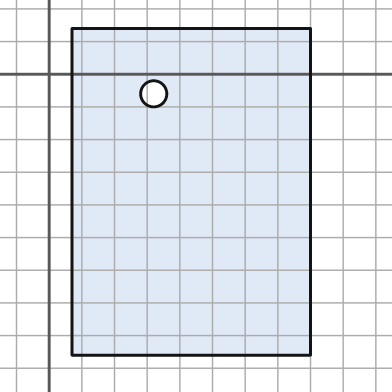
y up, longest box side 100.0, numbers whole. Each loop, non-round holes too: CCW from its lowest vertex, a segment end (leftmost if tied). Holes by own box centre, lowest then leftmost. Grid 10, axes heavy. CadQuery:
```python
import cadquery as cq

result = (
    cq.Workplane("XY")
    .moveTo(7.0, -86.0)
    .lineTo(80.0, -86.0)
    .lineTo(80.0, 14.0)
    .lineTo(7.0, 14.0)
    .close()
    .moveTo(32.0, -6.0)
    .circle(4.0)
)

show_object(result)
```